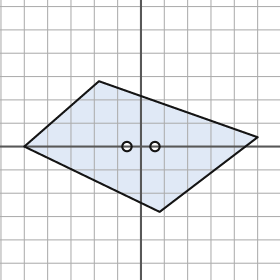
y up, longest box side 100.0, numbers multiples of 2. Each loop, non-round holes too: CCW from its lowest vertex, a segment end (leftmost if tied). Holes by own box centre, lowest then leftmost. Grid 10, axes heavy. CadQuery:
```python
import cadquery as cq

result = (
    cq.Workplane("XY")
    .moveTo(8.0, -28.0)
    .lineTo(50.0, 4.0)
    .lineTo(-18.0, 28.0)
    .lineTo(-50.0, 0.0)
    .close()
    .moveTo(-6.0, 0.0)
    .circle(2.0)
    .moveTo(6.0, 0.0)
    .circle(2.0)
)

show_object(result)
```